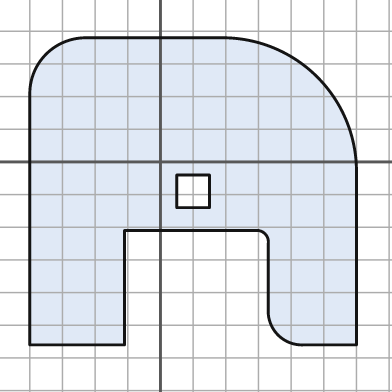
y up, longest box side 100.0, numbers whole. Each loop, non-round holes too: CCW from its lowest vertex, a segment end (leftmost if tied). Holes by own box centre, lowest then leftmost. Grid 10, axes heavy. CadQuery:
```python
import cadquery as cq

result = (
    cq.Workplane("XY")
    .moveTo(-40.0, -56.0)
    .lineTo(-11.0, -56.0)
    .lineTo(-11.0, -21.0)
    .lineTo(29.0, -21.0)
    .threePointArc((32.0, -22.0), (33.0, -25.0))
    .lineTo(33.0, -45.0)
    .threePointArc((36.0, -53.0), (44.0, -56.0))
    .lineTo(60.0, -56.0)
    .lineTo(60.0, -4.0)
    .threePointArc((48.0, 26.0), (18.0, 38.0))
    .lineTo(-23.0, 38.0)
    .threePointArc((-35.0, 33.0), (-40.0, 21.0))
    .close()
    .moveTo(5.0, -14.0)
    .lineTo(15.0, -14.0)
    .lineTo(15.0, -4.0)
    .lineTo(5.0, -4.0)
    .close()
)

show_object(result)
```